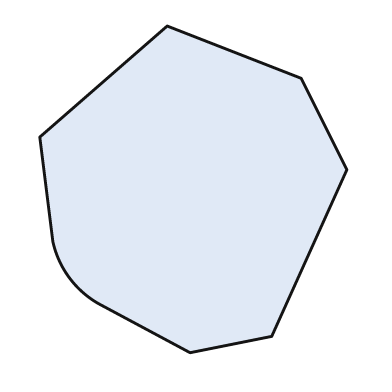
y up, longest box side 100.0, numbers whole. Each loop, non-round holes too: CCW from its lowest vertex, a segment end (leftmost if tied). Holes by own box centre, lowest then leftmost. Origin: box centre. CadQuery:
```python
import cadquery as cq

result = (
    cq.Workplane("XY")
    .moveTo(-1.0, -50.0)
    .lineTo(24.0, -45.0)
    .lineTo(47.0, 6.0)
    .lineTo(33.0, 34.0)
    .lineTo(-8.0, 50.0)
    .lineTo(-47.0, 16.0)
    .lineTo(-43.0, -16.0)
    .threePointArc((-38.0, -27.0), (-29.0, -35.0))
    .close()
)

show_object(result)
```